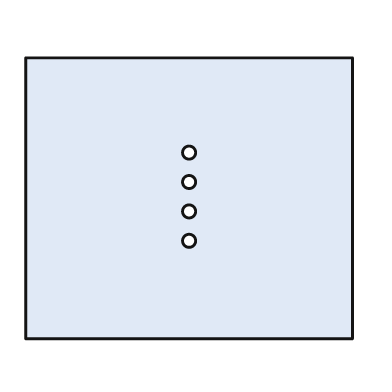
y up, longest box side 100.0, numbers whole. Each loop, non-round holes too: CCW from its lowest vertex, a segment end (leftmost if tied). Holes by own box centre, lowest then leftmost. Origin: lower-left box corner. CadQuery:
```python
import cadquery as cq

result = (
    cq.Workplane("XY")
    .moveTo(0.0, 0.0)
    .lineTo(100.0, 0.0)
    .lineTo(100.0, 86.0)
    .lineTo(0.0, 86.0)
    .close()
    .moveTo(50.0, 30.0)
    .circle(2.0)
    .moveTo(50.0, 39.0)
    .circle(2.0)
    .moveTo(50.0, 48.0)
    .circle(2.0)
    .moveTo(50.0, 57.0)
    .circle(2.0)
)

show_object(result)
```